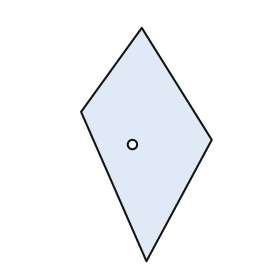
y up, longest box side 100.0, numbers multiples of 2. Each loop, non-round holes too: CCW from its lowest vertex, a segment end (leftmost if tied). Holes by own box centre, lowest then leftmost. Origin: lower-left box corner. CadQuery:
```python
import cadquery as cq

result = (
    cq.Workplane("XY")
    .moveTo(28.0, 0.0)
    .lineTo(56.0, 52.0)
    .lineTo(26.0, 100.0)
    .lineTo(0.0, 64.0)
    .close()
    .moveTo(22.0, 50.0)
    .circle(2.0)
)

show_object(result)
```